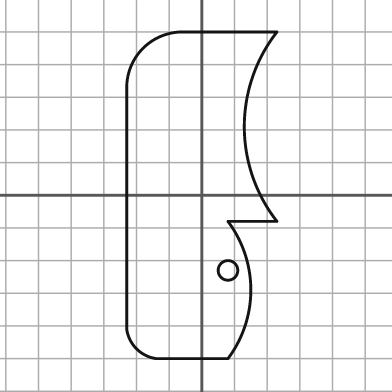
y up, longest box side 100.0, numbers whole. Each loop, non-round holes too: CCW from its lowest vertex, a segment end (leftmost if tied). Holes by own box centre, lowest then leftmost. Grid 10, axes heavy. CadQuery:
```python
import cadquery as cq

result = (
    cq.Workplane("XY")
    .moveTo(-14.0, -50.0)
    .lineTo(8.0, -50.0)
    .threePointArc((15.0, -29.0), (8.0, -8.0))
    .lineTo(23.0, -8.0)
    .threePointArc((13.0, 21.0), (23.0, 50.0))
    .lineTo(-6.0, 50.0)
    .threePointArc((-18.0, 45.0), (-23.0, 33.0))
    .lineTo(-23.0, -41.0)
    .threePointArc((-20.0, -47.0), (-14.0, -50.0))
    .close()
    .moveTo(8.0, -23.0)
    .circle(3.0)
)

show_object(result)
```